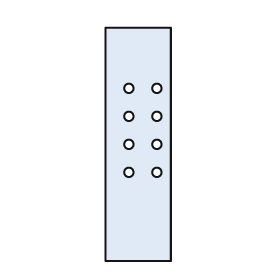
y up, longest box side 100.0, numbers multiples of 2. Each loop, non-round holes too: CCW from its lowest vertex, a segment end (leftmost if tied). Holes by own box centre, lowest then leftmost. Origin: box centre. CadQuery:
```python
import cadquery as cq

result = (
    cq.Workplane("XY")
    .moveTo(-14.0, -50.0)
    .lineTo(14.0, -50.0)
    .lineTo(14.0, 50.0)
    .lineTo(-14.0, 50.0)
    .close()
    .moveTo(-4.0, -12.0)
    .circle(2.0)
    .moveTo(8.0, -12.0)
    .circle(2.0)
    .moveTo(-4.0, 0.0)
    .circle(2.0)
    .moveTo(8.0, 0.0)
    .circle(2.0)
    .moveTo(-4.0, 12.0)
    .circle(2.0)
    .moveTo(8.0, 12.0)
    .circle(2.0)
    .moveTo(-4.0, 24.0)
    .circle(2.0)
    .moveTo(8.0, 24.0)
    .circle(2.0)
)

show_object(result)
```